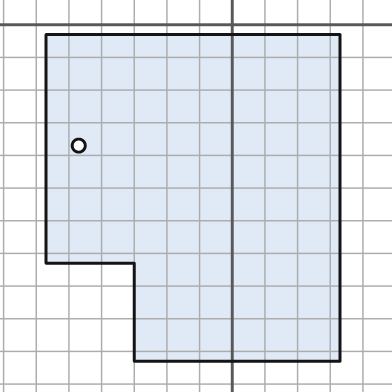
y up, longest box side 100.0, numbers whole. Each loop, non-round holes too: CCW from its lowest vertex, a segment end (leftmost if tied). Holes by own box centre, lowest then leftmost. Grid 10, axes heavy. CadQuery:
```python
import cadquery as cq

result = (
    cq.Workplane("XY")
    .moveTo(-30.0, -103.0)
    .lineTo(33.0, -103.0)
    .lineTo(33.0, -3.0)
    .lineTo(-57.0, -3.0)
    .lineTo(-57.0, -73.0)
    .lineTo(-30.0, -73.0)
    .close()
    .moveTo(-47.0, -37.0)
    .circle(2.0)
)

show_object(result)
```